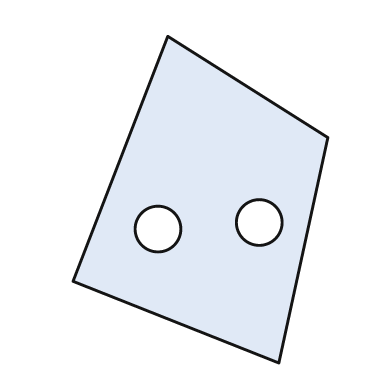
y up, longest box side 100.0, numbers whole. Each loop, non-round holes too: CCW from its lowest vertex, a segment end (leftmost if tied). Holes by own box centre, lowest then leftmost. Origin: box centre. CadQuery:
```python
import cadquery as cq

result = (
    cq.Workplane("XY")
    .moveTo(24.0, -50.0)
    .lineTo(39.0, 19.0)
    .lineTo(-10.0, 50.0)
    .lineTo(-39.0, -25.0)
    .close()
    .moveTo(-13.0, -9.0)
    .circle(7.0)
    .moveTo(18.0, -7.0)
    .circle(7.0)
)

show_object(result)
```